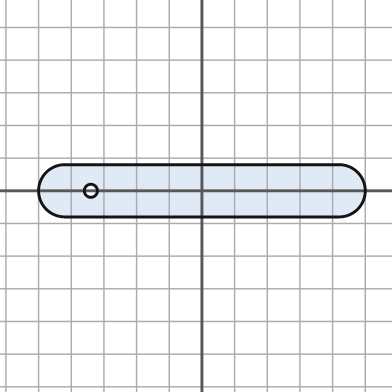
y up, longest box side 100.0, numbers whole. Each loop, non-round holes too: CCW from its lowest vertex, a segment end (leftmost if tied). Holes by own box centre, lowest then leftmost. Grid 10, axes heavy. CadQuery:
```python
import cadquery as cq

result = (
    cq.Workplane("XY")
    .moveTo(-42.0, -8.0)
    .lineTo(42.0, -8.0)
    .threePointArc((50.0, 0.0), (42.0, 8.0))
    .lineTo(-42.0, 8.0)
    .threePointArc((-50.0, 0.0), (-42.0, -8.0))
    .close()
    .moveTo(-34.0, 0.0)
    .circle(2.0)
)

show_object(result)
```